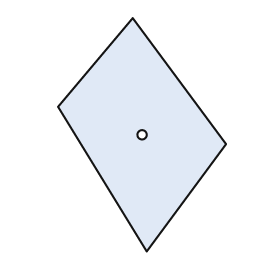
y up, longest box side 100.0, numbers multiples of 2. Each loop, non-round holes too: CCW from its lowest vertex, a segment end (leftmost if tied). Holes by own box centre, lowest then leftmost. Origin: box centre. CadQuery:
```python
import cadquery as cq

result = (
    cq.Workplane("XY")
    .moveTo(2.0, -50.0)
    .lineTo(36.0, -4.0)
    .lineTo(-4.0, 50.0)
    .lineTo(-36.0, 12.0)
    .close()
    .moveTo(0.0, 0.0)
    .circle(2.0)
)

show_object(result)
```